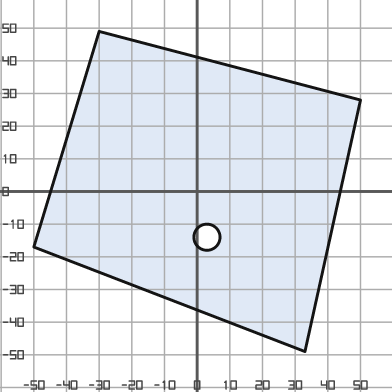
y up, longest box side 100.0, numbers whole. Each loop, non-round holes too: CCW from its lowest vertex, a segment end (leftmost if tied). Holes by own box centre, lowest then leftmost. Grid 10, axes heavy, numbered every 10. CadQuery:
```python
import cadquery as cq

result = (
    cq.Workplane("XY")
    .moveTo(33.0, -49.0)
    .lineTo(50.0, 28.0)
    .lineTo(-30.0, 49.0)
    .lineTo(-50.0, -17.0)
    .close()
    .moveTo(3.0, -14.0)
    .circle(4.0)
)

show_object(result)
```